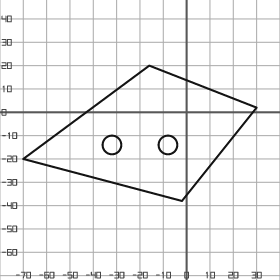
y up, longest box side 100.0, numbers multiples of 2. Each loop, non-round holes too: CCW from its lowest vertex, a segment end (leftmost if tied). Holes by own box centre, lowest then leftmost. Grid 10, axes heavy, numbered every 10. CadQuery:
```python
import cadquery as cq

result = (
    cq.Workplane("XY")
    .moveTo(-2.0, -38.0)
    .lineTo(30.0, 2.0)
    .lineTo(-16.0, 20.0)
    .lineTo(-70.0, -20.0)
    .close()
    .moveTo(-32.0, -14.0)
    .circle(4.0)
    .moveTo(-8.0, -14.0)
    .circle(4.0)
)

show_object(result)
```